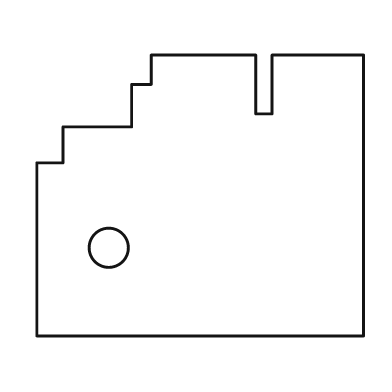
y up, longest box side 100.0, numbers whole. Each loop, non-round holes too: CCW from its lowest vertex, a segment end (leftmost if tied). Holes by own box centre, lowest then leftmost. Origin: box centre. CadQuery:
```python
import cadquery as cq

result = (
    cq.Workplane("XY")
    .moveTo(-50.0, -43.0)
    .lineTo(50.0, -43.0)
    .lineTo(50.0, 43.0)
    .lineTo(22.0, 43.0)
    .lineTo(22.0, 25.0)
    .lineTo(17.0, 25.0)
    .lineTo(17.0, 43.0)
    .lineTo(-15.0, 43.0)
    .lineTo(-15.0, 34.0)
    .lineTo(-21.0, 34.0)
    .lineTo(-21.0, 21.0)
    .lineTo(-42.0, 21.0)
    .lineTo(-42.0, 10.0)
    .lineTo(-50.0, 10.0)
    .close()
    .moveTo(-28.0, -16.0)
    .circle(6.0)
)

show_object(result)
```